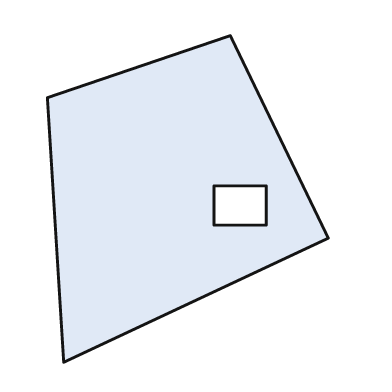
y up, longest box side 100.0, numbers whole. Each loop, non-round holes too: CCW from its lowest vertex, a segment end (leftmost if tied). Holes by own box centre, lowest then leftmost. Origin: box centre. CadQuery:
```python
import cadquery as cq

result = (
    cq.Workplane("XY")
    .moveTo(-38.0, -50.0)
    .lineTo(43.0, -12.0)
    .lineTo(13.0, 50.0)
    .lineTo(-43.0, 31.0)
    .close()
    .moveTo(8.0, -8.0)
    .lineTo(24.0, -8.0)
    .lineTo(24.0, 4.0)
    .lineTo(8.0, 4.0)
    .close()
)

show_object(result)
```